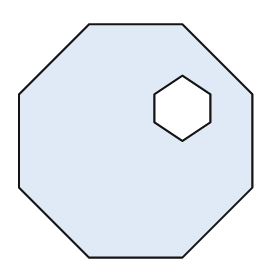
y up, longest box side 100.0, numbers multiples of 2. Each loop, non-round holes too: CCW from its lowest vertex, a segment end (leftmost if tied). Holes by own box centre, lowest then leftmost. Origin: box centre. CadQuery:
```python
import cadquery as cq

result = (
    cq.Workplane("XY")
    .moveTo(-20.0, -50.0)
    .lineTo(20.0, -50.0)
    .lineTo(50.0, -20.0)
    .lineTo(50.0, 20.0)
    .lineTo(20.0, 50.0)
    .lineTo(-20.0, 50.0)
    .lineTo(-50.0, 20.0)
    .lineTo(-50.0, -20.0)
    .close()
    .moveTo(20.0, 0.0)
    .lineTo(32.0, 8.0)
    .lineTo(32.0, 20.0)
    .lineTo(20.0, 28.0)
    .lineTo(8.0, 20.0)
    .lineTo(8.0, 8.0)
    .close()
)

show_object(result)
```